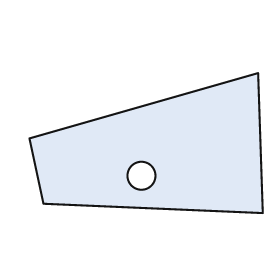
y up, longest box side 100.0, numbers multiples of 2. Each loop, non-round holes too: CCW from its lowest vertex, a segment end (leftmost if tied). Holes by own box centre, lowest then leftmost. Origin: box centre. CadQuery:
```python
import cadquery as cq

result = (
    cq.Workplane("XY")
    .moveTo(50.0, -30.0)
    .lineTo(48.0, 30.0)
    .lineTo(-50.0, 2.0)
    .lineTo(-44.0, -26.0)
    .close()
    .moveTo(-2.0, -14.0)
    .circle(6.0)
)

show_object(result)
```